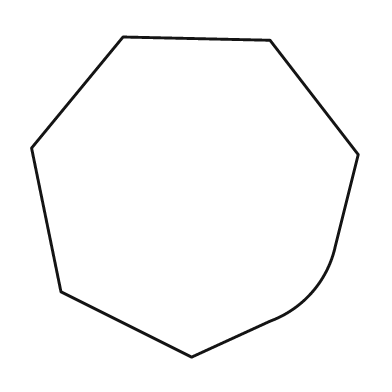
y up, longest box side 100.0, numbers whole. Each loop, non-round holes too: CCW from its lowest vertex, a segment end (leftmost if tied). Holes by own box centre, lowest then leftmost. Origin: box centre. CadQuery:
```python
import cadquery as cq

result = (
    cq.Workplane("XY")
    .moveTo(-1.0, -49.0)
    .lineTo(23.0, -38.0)
    .threePointArc((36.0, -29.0), (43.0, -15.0))
    .lineTo(50.0, 13.0)
    .lineTo(23.0, 48.0)
    .lineTo(-22.0, 49.0)
    .lineTo(-50.0, 15.0)
    .lineTo(-41.0, -29.0)
    .close()
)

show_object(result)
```